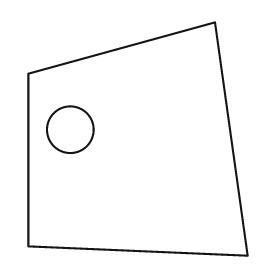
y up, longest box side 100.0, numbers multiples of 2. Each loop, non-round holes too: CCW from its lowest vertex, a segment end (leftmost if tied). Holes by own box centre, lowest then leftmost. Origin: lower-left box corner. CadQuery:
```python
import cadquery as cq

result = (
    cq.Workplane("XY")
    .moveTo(94.0, 0.0)
    .lineTo(80.0, 100.0)
    .lineTo(0.0, 78.0)
    .lineTo(0.0, 4.0)
    .close()
    .moveTo(18.0, 54.0)
    .circle(10.0)
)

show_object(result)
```